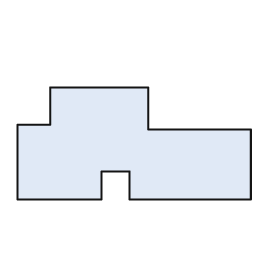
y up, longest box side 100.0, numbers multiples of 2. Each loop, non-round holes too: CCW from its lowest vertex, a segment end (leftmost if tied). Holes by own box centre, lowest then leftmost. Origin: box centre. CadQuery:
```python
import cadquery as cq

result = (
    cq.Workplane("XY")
    .moveTo(-50.0, -24.0)
    .lineTo(-14.0, -24.0)
    .lineTo(-14.0, -12.0)
    .lineTo(-2.0, -12.0)
    .lineTo(-2.0, -24.0)
    .lineTo(50.0, -24.0)
    .lineTo(50.0, 6.0)
    .lineTo(6.0, 6.0)
    .lineTo(6.0, 24.0)
    .lineTo(-36.0, 24.0)
    .lineTo(-36.0, 8.0)
    .lineTo(-50.0, 8.0)
    .close()
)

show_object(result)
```